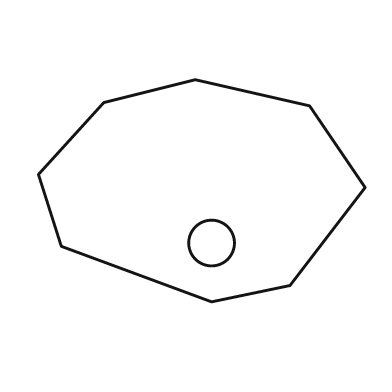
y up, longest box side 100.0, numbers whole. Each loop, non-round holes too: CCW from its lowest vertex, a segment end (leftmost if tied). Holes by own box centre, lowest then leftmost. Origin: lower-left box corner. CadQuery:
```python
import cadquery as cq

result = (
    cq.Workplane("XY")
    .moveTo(53.0, 0.0)
    .lineTo(77.0, 5.0)
    .lineTo(100.0, 35.0)
    .lineTo(83.0, 60.0)
    .lineTo(48.0, 68.0)
    .lineTo(20.0, 61.0)
    .lineTo(0.0, 39.0)
    .lineTo(7.0, 17.0)
    .close()
    .moveTo(53.0, 18.0)
    .circle(7.0)
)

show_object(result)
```